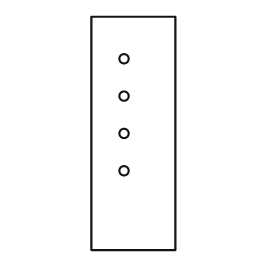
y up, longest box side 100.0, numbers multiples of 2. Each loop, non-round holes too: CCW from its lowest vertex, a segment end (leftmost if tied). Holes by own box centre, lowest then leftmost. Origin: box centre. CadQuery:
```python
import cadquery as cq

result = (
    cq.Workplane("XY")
    .moveTo(-18.0, -50.0)
    .lineTo(18.0, -50.0)
    .lineTo(18.0, 50.0)
    .lineTo(-18.0, 50.0)
    .close()
    .moveTo(-4.0, -16.0)
    .circle(2.0)
    .moveTo(-4.0, 0.0)
    .circle(2.0)
    .moveTo(-4.0, 16.0)
    .circle(2.0)
    .moveTo(-4.0, 32.0)
    .circle(2.0)
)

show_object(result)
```